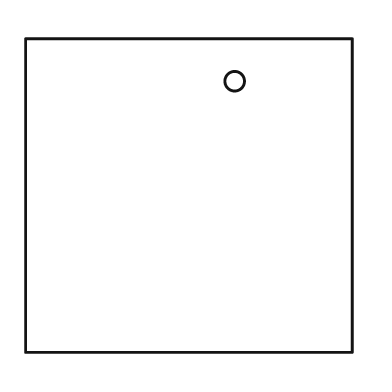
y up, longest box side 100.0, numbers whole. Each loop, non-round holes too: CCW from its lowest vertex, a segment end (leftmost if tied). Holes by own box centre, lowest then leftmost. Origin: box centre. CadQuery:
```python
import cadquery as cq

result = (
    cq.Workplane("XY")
    .moveTo(-50.0, -48.0)
    .lineTo(50.0, -48.0)
    .lineTo(50.0, 48.0)
    .lineTo(-50.0, 48.0)
    .close()
    .moveTo(14.0, 35.0)
    .circle(3.0)
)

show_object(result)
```